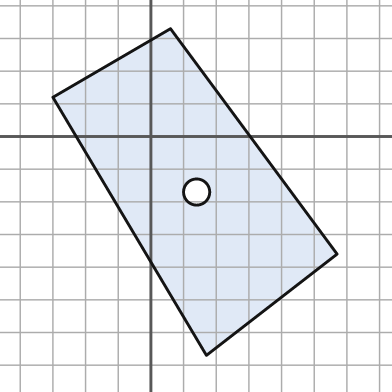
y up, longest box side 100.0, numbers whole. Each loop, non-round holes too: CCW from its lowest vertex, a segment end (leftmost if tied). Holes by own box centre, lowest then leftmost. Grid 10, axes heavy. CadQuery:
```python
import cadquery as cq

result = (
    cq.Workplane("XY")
    .moveTo(17.0, -67.0)
    .lineTo(57.0, -36.0)
    .lineTo(6.0, 33.0)
    .lineTo(-30.0, 12.0)
    .close()
    .moveTo(14.0, -17.0)
    .circle(4.0)
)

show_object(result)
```